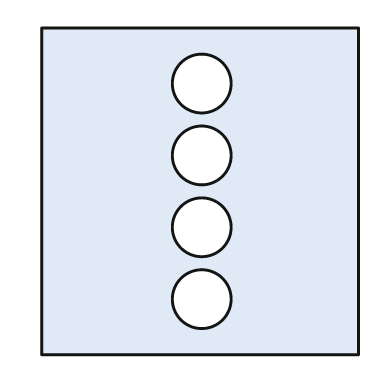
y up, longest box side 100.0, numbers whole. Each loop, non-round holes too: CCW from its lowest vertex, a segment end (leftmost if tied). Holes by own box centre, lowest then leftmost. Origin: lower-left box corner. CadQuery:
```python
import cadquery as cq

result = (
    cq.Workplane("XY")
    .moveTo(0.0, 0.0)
    .lineTo(97.0, 0.0)
    .lineTo(97.0, 100.0)
    .lineTo(0.0, 100.0)
    .close()
    .moveTo(49.0, 17.0)
    .circle(9.0)
    .moveTo(49.0, 39.0)
    .circle(9.0)
    .moveTo(49.0, 61.0)
    .circle(9.0)
    .moveTo(49.0, 83.0)
    .circle(9.0)
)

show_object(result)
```